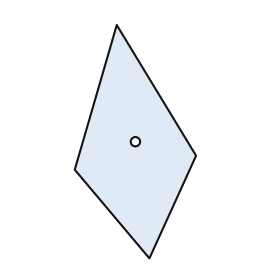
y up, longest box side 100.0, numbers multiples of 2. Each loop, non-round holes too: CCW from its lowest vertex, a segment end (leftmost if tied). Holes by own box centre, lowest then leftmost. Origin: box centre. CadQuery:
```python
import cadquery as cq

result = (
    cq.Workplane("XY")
    .moveTo(6.0, -50.0)
    .lineTo(26.0, -6.0)
    .lineTo(-8.0, 50.0)
    .lineTo(-26.0, -12.0)
    .close()
    .moveTo(0.0, 0.0)
    .circle(2.0)
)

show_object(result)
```